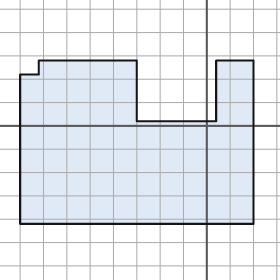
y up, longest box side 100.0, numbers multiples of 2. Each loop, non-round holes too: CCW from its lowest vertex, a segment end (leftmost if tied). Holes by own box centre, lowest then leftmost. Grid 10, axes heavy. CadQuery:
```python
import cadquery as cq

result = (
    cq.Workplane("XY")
    .moveTo(-80.0, -42.0)
    .lineTo(20.0, -42.0)
    .lineTo(20.0, 28.0)
    .lineTo(4.0, 28.0)
    .lineTo(4.0, 2.0)
    .lineTo(-30.0, 2.0)
    .lineTo(-30.0, 28.0)
    .lineTo(-72.0, 28.0)
    .lineTo(-72.0, 22.0)
    .lineTo(-80.0, 22.0)
    .close()
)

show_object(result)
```